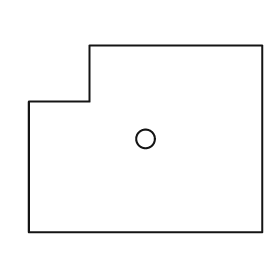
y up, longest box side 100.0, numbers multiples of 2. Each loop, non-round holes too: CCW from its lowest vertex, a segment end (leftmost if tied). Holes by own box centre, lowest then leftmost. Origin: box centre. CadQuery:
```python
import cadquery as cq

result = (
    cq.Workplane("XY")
    .moveTo(-50.0, -40.0)
    .lineTo(50.0, -40.0)
    .lineTo(50.0, 40.0)
    .lineTo(-24.0, 40.0)
    .lineTo(-24.0, 16.0)
    .lineTo(-50.0, 16.0)
    .close()
    .moveTo(0.0, 0.0)
    .circle(4.0)
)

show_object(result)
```